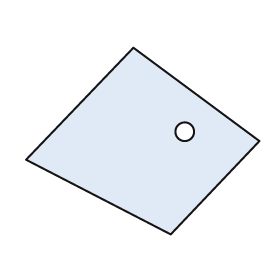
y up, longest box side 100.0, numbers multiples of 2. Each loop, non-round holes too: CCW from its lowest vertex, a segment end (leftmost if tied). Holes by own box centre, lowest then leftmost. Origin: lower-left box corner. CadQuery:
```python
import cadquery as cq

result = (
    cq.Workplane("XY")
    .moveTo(62.0, 0.0)
    .lineTo(100.0, 40.0)
    .lineTo(46.0, 80.0)
    .lineTo(0.0, 32.0)
    .close()
    .moveTo(68.0, 44.0)
    .circle(4.0)
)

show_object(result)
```